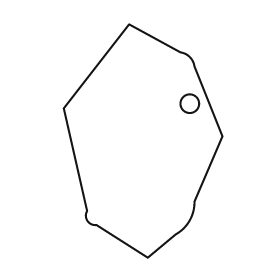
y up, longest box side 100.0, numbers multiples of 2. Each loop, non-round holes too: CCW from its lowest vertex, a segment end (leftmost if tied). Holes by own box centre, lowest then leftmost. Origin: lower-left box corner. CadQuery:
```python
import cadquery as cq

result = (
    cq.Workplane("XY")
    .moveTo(36.0, 0.0)
    .lineTo(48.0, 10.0)
    .threePointArc((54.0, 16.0), (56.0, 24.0))
    .lineTo(68.0, 52.0)
    .lineTo(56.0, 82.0)
    .threePointArc((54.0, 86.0), (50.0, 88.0))
    .lineTo(28.0, 100.0)
    .lineTo(0.0, 64.0)
    .lineTo(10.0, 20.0)
    .threePointArc((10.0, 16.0), (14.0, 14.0))
    .close()
    .moveTo(54.0, 66.0)
    .circle(4.0)
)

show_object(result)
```